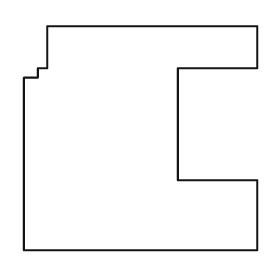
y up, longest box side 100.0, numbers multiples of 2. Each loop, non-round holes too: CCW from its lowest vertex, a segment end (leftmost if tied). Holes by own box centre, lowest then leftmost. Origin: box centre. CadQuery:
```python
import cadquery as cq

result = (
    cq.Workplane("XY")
    .moveTo(-50.0, -48.0)
    .lineTo(50.0, -48.0)
    .lineTo(50.0, -18.0)
    .lineTo(16.0, -18.0)
    .lineTo(16.0, 30.0)
    .lineTo(50.0, 30.0)
    .lineTo(50.0, 48.0)
    .lineTo(-40.0, 48.0)
    .lineTo(-40.0, 30.0)
    .lineTo(-44.0, 30.0)
    .lineTo(-44.0, 26.0)
    .lineTo(-50.0, 26.0)
    .close()
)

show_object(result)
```